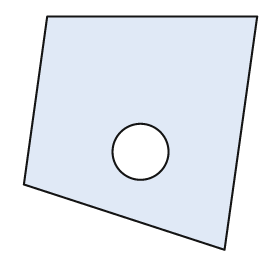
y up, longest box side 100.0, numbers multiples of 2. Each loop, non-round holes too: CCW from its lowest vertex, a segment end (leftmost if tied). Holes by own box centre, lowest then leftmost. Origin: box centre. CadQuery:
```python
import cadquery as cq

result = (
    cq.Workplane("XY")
    .moveTo(36.0, -50.0)
    .lineTo(50.0, 50.0)
    .lineTo(-40.0, 50.0)
    .lineTo(-50.0, -22.0)
    .close()
    .moveTo(0.0, -8.0)
    .circle(12.0)
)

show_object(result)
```